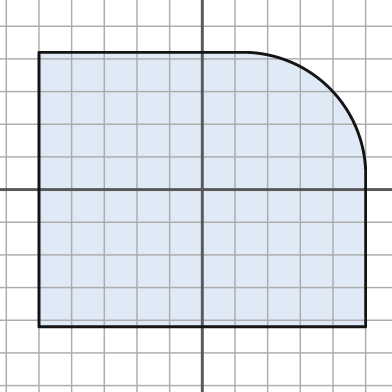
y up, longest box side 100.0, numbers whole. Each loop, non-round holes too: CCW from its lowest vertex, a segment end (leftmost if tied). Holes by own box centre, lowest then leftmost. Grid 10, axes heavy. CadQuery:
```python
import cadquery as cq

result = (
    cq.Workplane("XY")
    .moveTo(-50.0, -42.0)
    .lineTo(50.0, -42.0)
    .lineTo(50.0, 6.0)
    .threePointArc((39.0, 31.0), (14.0, 42.0))
    .lineTo(-50.0, 42.0)
    .close()
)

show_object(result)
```